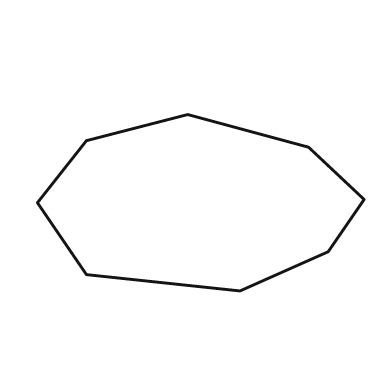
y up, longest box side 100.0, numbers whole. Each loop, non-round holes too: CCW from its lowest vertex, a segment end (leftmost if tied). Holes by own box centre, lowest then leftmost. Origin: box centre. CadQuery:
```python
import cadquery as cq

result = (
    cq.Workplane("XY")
    .moveTo(12.0, -27.0)
    .lineTo(39.0, -15.0)
    .lineTo(50.0, 1.0)
    .lineTo(33.0, 17.0)
    .lineTo(-4.0, 27.0)
    .lineTo(-35.0, 19.0)
    .lineTo(-50.0, 0.0)
    .lineTo(-35.0, -22.0)
    .close()
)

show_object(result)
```